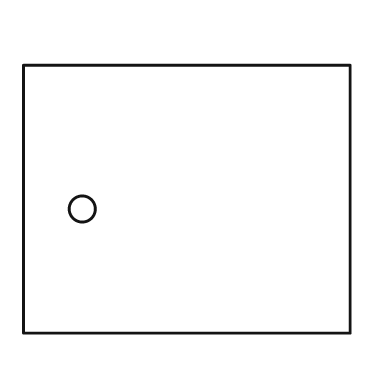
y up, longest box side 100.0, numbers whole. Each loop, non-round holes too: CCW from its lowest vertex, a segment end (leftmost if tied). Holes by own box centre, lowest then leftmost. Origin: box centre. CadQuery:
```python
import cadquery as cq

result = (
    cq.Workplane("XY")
    .moveTo(-50.0, -41.0)
    .lineTo(50.0, -41.0)
    .lineTo(50.0, 41.0)
    .lineTo(-50.0, 41.0)
    .close()
    .moveTo(-32.0, -3.0)
    .circle(4.0)
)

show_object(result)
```